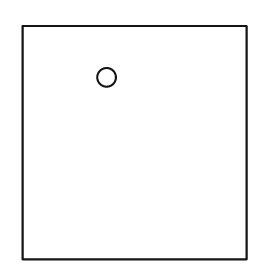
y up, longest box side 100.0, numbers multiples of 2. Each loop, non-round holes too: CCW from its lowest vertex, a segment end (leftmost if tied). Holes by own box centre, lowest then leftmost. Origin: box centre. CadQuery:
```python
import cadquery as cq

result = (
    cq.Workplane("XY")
    .moveTo(-48.0, -50.0)
    .lineTo(48.0, -50.0)
    .lineTo(48.0, 50.0)
    .lineTo(-48.0, 50.0)
    .close()
    .moveTo(-12.0, 28.0)
    .circle(4.0)
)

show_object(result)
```